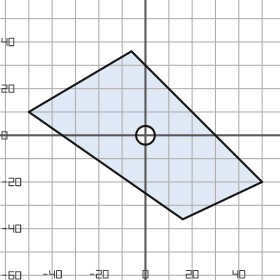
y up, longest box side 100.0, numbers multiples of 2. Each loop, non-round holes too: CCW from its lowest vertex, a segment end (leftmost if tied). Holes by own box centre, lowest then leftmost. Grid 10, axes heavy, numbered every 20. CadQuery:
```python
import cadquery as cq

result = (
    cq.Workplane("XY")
    .moveTo(16.0, -36.0)
    .lineTo(50.0, -20.0)
    .lineTo(-6.0, 36.0)
    .lineTo(-50.0, 10.0)
    .close()
    .moveTo(0.0, 0.0)
    .circle(4.0)
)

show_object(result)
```